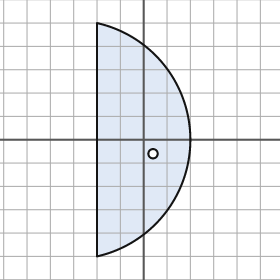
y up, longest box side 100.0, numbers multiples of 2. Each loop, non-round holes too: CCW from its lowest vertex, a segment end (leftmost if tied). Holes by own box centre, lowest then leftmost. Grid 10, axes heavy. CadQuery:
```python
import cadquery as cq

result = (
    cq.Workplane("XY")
    .moveTo(-20.0, -50.0)
    .threePointArc((20.0, 0.0), (-20.0, 50.0))
    .close()
    .moveTo(4.0, -6.0)
    .circle(2.0)
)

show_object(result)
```